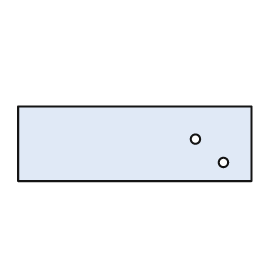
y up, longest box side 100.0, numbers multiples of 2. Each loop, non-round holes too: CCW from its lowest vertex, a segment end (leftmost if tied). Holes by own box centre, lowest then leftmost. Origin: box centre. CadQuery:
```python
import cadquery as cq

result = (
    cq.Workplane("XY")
    .moveTo(-50.0, -16.0)
    .lineTo(50.0, -16.0)
    .lineTo(50.0, 16.0)
    .lineTo(-50.0, 16.0)
    .close()
    .moveTo(38.0, -8.0)
    .circle(2.0)
    .moveTo(26.0, 2.0)
    .circle(2.0)
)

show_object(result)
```